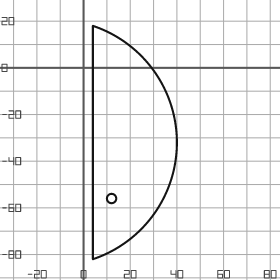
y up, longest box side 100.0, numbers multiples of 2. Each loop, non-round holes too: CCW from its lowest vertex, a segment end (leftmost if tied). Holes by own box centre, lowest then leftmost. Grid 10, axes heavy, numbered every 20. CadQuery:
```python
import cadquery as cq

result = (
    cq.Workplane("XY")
    .moveTo(4.0, -82.0)
    .threePointArc((40.0, -32.0), (4.0, 18.0))
    .close()
    .moveTo(12.0, -56.0)
    .circle(2.0)
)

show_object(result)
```